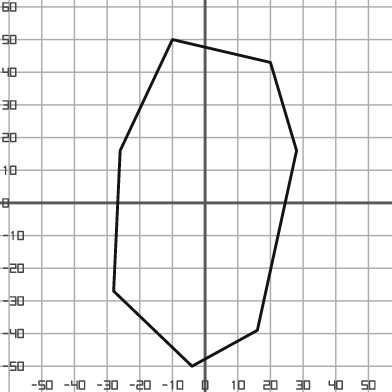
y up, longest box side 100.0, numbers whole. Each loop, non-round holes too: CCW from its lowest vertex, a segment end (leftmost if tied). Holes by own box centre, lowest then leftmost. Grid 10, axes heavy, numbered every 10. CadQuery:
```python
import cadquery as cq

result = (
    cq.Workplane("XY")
    .moveTo(-4.0, -50.0)
    .lineTo(16.0, -39.0)
    .lineTo(28.0, 16.0)
    .lineTo(20.0, 43.0)
    .lineTo(-10.0, 50.0)
    .lineTo(-26.0, 16.0)
    .lineTo(-28.0, -27.0)
    .close()
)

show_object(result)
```